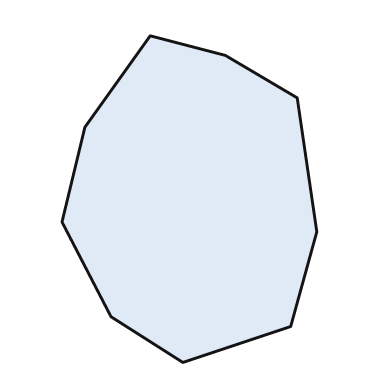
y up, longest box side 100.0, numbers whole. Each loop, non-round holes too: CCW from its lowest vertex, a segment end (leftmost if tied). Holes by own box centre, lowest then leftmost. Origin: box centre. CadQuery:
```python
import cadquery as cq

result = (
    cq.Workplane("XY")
    .moveTo(-2.0, -50.0)
    .lineTo(31.0, -39.0)
    .lineTo(39.0, -10.0)
    .lineTo(33.0, 31.0)
    .lineTo(11.0, 44.0)
    .lineTo(-12.0, 50.0)
    .lineTo(-32.0, 22.0)
    .lineTo(-39.0, -7.0)
    .lineTo(-24.0, -36.0)
    .close()
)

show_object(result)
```